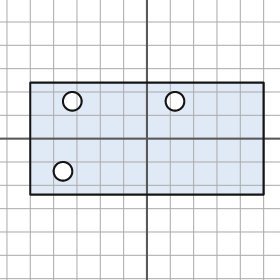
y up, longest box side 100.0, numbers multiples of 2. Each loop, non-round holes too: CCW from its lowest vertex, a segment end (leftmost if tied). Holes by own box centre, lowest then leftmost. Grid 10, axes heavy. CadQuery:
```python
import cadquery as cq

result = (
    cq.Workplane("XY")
    .moveTo(-50.0, -24.0)
    .lineTo(50.0, -24.0)
    .lineTo(50.0, 24.0)
    .lineTo(-50.0, 24.0)
    .close()
    .moveTo(-36.0, -14.0)
    .circle(4.0)
    .moveTo(-32.0, 16.0)
    .circle(4.0)
    .moveTo(12.0, 16.0)
    .circle(4.0)
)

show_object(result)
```